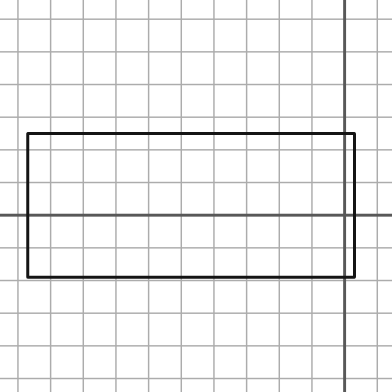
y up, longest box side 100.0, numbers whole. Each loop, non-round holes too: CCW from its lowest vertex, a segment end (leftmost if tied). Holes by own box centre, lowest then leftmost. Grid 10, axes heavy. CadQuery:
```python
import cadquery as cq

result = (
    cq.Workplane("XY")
    .moveTo(-97.0, -19.0)
    .lineTo(3.0, -19.0)
    .lineTo(3.0, 25.0)
    .lineTo(-97.0, 25.0)
    .close()
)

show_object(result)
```